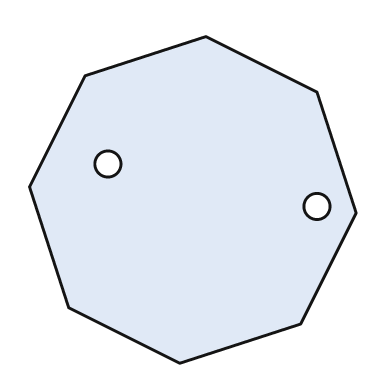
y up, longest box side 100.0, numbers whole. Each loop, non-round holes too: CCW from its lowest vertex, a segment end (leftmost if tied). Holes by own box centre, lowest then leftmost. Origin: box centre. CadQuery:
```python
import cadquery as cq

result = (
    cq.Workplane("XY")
    .moveTo(-4.0, -50.0)
    .lineTo(33.0, -38.0)
    .lineTo(50.0, -4.0)
    .lineTo(38.0, 33.0)
    .lineTo(4.0, 50.0)
    .lineTo(-33.0, 38.0)
    .lineTo(-50.0, 4.0)
    .lineTo(-38.0, -33.0)
    .close()
    .moveTo(38.0, -2.0)
    .circle(4.0)
    .moveTo(-26.0, 11.0)
    .circle(4.0)
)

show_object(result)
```